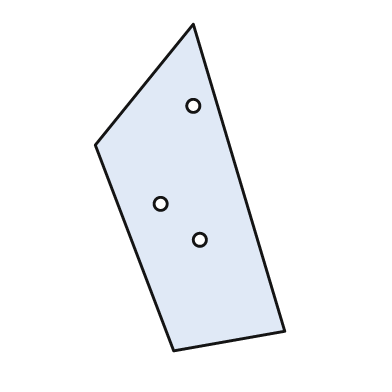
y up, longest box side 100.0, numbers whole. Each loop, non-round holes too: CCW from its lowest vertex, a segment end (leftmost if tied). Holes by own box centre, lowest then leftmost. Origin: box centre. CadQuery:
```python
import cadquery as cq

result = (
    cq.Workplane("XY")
    .moveTo(-5.0, -50.0)
    .lineTo(29.0, -44.0)
    .lineTo(1.0, 50.0)
    .lineTo(-29.0, 13.0)
    .close()
    .moveTo(3.0, -16.0)
    .circle(2.0)
    .moveTo(-9.0, -5.0)
    .circle(2.0)
    .moveTo(1.0, 25.0)
    .circle(2.0)
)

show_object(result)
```